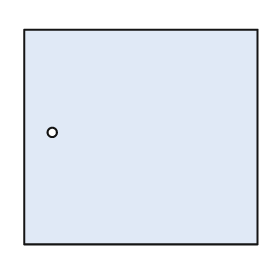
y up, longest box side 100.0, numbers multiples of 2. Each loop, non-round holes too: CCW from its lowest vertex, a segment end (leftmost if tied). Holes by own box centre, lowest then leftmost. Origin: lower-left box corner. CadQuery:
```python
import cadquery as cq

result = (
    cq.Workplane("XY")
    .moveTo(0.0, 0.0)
    .lineTo(100.0, 0.0)
    .lineTo(100.0, 92.0)
    .lineTo(0.0, 92.0)
    .close()
    .moveTo(12.0, 48.0)
    .circle(2.0)
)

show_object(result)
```